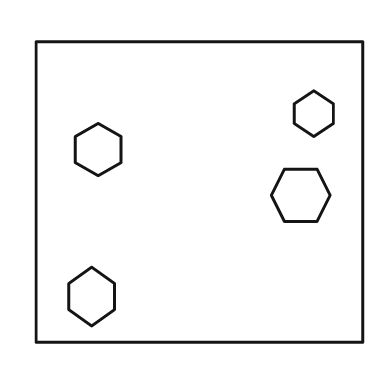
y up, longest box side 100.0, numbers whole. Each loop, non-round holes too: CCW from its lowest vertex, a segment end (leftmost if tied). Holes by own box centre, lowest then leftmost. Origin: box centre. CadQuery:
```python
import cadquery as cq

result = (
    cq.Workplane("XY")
    .moveTo(-50.0, -46.0)
    .lineTo(50.0, -46.0)
    .lineTo(50.0, 46.0)
    .lineTo(-50.0, 46.0)
    .close()
    .moveTo(-33.0, -41.0)
    .lineTo(-26.0, -36.0)
    .lineTo(-26.0, -28.0)
    .lineTo(-33.0, -23.0)
    .lineTo(-40.0, -28.0)
    .lineTo(-40.0, -36.0)
    .close()
    .moveTo(26.0, -9.0)
    .lineTo(36.0, -9.0)
    .lineTo(40.0, -1.0)
    .lineTo(36.0, 7.0)
    .lineTo(26.0, 7.0)
    .lineTo(22.0, -1.0)
    .close()
    .moveTo(-31.0, 5.0)
    .lineTo(-24.0, 9.0)
    .lineTo(-24.0, 17.0)
    .lineTo(-31.0, 21.0)
    .lineTo(-38.0, 17.0)
    .lineTo(-38.0, 9.0)
    .close()
    .moveTo(35.0, 17.0)
    .lineTo(41.0, 21.0)
    .lineTo(41.0, 27.0)
    .lineTo(35.0, 31.0)
    .lineTo(29.0, 27.0)
    .lineTo(29.0, 21.0)
    .close()
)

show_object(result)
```